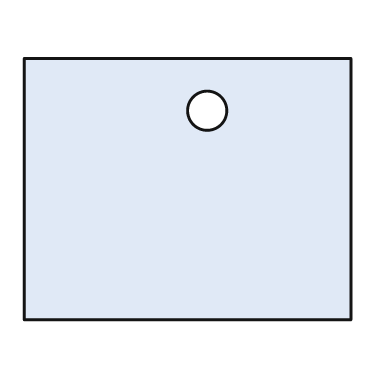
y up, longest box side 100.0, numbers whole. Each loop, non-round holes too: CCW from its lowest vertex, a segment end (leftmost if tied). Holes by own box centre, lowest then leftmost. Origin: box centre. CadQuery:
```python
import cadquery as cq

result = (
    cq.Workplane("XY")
    .moveTo(-50.0, -40.0)
    .lineTo(50.0, -40.0)
    .lineTo(50.0, 40.0)
    .lineTo(-50.0, 40.0)
    .close()
    .moveTo(6.0, 24.0)
    .circle(6.0)
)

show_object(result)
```